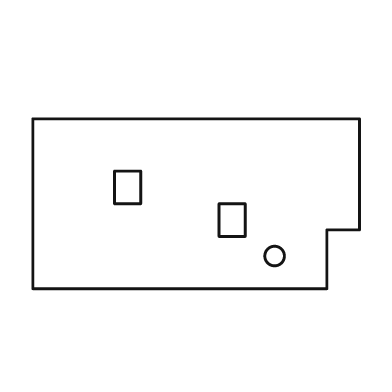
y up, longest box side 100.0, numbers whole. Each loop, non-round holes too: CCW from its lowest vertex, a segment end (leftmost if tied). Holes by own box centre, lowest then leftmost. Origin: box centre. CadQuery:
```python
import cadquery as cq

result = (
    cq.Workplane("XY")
    .moveTo(-50.0, -26.0)
    .lineTo(40.0, -26.0)
    .lineTo(40.0, -8.0)
    .lineTo(50.0, -8.0)
    .lineTo(50.0, 26.0)
    .lineTo(-50.0, 26.0)
    .close()
    .moveTo(24.0, -16.0)
    .circle(3.0)
    .moveTo(7.0, -10.0)
    .lineTo(15.0, -10.0)
    .lineTo(15.0, 0.0)
    .lineTo(7.0, 0.0)
    .close()
    .moveTo(-25.0, 0.0)
    .lineTo(-17.0, 0.0)
    .lineTo(-17.0, 10.0)
    .lineTo(-25.0, 10.0)
    .close()
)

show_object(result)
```